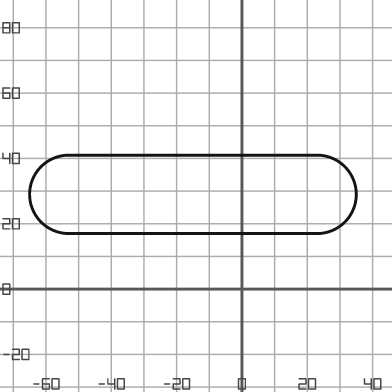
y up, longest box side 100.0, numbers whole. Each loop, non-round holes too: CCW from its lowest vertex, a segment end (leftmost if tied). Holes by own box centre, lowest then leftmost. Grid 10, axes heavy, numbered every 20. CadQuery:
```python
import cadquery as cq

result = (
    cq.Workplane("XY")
    .moveTo(-53.0, 17.0)
    .lineTo(23.0, 17.0)
    .threePointArc((35.0, 29.0), (23.0, 41.0))
    .lineTo(-53.0, 41.0)
    .threePointArc((-65.0, 29.0), (-53.0, 17.0))
    .close()
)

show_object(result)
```